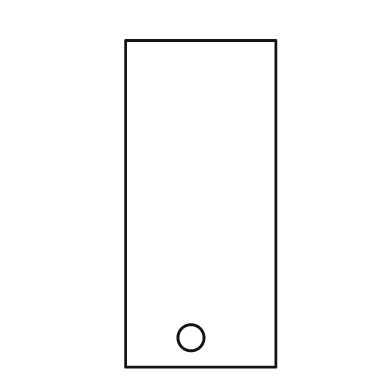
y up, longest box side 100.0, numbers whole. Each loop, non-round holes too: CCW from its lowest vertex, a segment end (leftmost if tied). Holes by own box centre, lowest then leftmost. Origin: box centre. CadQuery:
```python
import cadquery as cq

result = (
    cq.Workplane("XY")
    .moveTo(-23.0, -50.0)
    .lineTo(23.0, -50.0)
    .lineTo(23.0, 50.0)
    .lineTo(-23.0, 50.0)
    .close()
    .moveTo(-3.0, -41.0)
    .circle(4.0)
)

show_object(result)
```